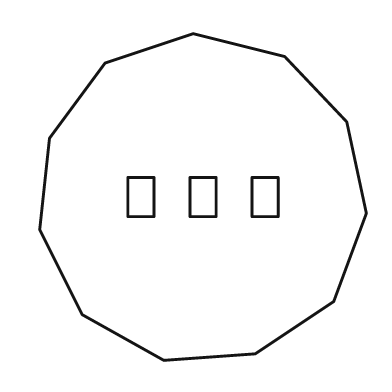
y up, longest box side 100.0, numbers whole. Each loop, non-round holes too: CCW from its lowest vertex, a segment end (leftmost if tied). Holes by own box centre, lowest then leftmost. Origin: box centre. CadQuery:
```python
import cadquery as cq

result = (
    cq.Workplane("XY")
    .moveTo(-12.0, -50.0)
    .lineTo(16.0, -48.0)
    .lineTo(40.0, -32.0)
    .lineTo(50.0, -5.0)
    .lineTo(44.0, 23.0)
    .lineTo(25.0, 43.0)
    .lineTo(-3.0, 50.0)
    .lineTo(-30.0, 41.0)
    .lineTo(-47.0, 18.0)
    .lineTo(-50.0, -10.0)
    .lineTo(-37.0, -36.0)
    .close()
    .moveTo(-23.0, -6.0)
    .lineTo(-15.0, -6.0)
    .lineTo(-15.0, 6.0)
    .lineTo(-23.0, 6.0)
    .close()
    .moveTo(-4.0, -6.0)
    .lineTo(4.0, -6.0)
    .lineTo(4.0, 6.0)
    .lineTo(-4.0, 6.0)
    .close()
    .moveTo(15.0, -6.0)
    .lineTo(23.0, -6.0)
    .lineTo(23.0, 6.0)
    .lineTo(15.0, 6.0)
    .close()
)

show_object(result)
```